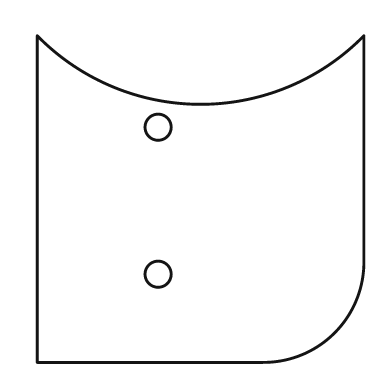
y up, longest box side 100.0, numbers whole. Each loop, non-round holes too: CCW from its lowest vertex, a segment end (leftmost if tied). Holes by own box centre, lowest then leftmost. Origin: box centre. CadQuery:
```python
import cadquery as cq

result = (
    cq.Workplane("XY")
    .moveTo(-50.0, -50.0)
    .lineTo(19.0, -50.0)
    .threePointArc((41.0, -41.0), (50.0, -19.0))
    .lineTo(50.0, 50.0)
    .threePointArc((0.0, 29.0), (-50.0, 50.0))
    .close()
    .moveTo(-13.0, -23.0)
    .circle(4.0)
    .moveTo(-13.0, 22.0)
    .circle(4.0)
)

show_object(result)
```